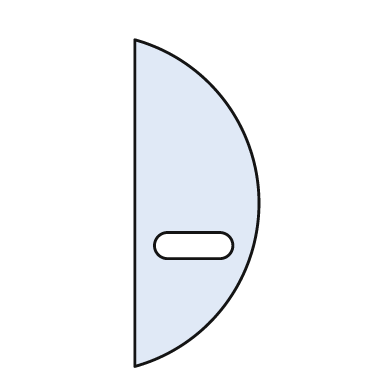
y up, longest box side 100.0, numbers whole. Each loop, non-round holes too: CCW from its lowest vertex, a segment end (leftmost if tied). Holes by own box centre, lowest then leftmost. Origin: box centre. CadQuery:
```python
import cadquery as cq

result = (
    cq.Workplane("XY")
    .moveTo(-19.0, -50.0)
    .threePointArc((19.0, 0.0), (-19.0, 50.0))
    .close()
    .moveTo(-9.0, -17.0)
    .lineTo(7.0, -17.0)
    .threePointArc((11.0, -13.0), (7.0, -9.0))
    .lineTo(-9.0, -9.0)
    .threePointArc((-13.0, -13.0), (-9.0, -17.0))
    .close()
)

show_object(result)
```